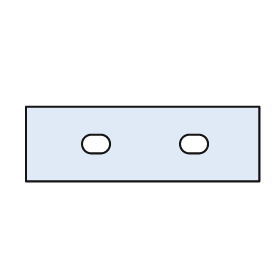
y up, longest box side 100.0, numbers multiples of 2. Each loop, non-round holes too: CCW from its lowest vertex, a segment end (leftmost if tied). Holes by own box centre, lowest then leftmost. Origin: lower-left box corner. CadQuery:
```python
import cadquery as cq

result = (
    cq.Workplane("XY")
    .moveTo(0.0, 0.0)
    .lineTo(100.0, 0.0)
    .lineTo(100.0, 32.0)
    .lineTo(0.0, 32.0)
    .close()
    .moveTo(28.0, 12.0)
    .lineTo(32.0, 12.0)
    .threePointArc((36.0, 16.0), (32.0, 20.0))
    .lineTo(28.0, 20.0)
    .threePointArc((24.0, 16.0), (28.0, 12.0))
    .close()
    .moveTo(70.0, 12.0)
    .lineTo(74.0, 12.0)
    .threePointArc((78.0, 16.0), (74.0, 20.0))
    .lineTo(70.0, 20.0)
    .threePointArc((66.0, 16.0), (70.0, 12.0))
    .close()
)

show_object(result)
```